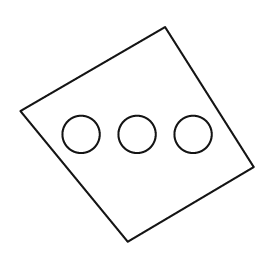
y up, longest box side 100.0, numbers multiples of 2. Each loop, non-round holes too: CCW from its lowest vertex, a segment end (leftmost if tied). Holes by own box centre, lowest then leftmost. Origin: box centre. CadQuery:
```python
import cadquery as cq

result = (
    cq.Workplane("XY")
    .moveTo(-4.0, -46.0)
    .lineTo(50.0, -14.0)
    .lineTo(12.0, 46.0)
    .lineTo(-50.0, 10.0)
    .close()
    .moveTo(-24.0, 0.0)
    .circle(8.0)
    .moveTo(0.0, 0.0)
    .circle(8.0)
    .moveTo(24.0, 0.0)
    .circle(8.0)
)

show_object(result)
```